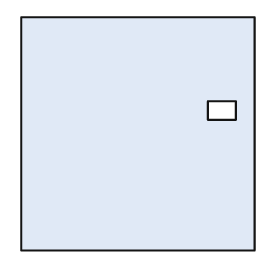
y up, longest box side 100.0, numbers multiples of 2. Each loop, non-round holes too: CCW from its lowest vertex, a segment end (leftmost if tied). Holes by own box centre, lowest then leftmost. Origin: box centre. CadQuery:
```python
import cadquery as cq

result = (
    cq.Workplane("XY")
    .moveTo(-50.0, -50.0)
    .lineTo(50.0, -50.0)
    .lineTo(50.0, 50.0)
    .lineTo(-50.0, 50.0)
    .close()
    .moveTo(30.0, 6.0)
    .lineTo(42.0, 6.0)
    .lineTo(42.0, 14.0)
    .lineTo(30.0, 14.0)
    .close()
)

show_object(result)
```